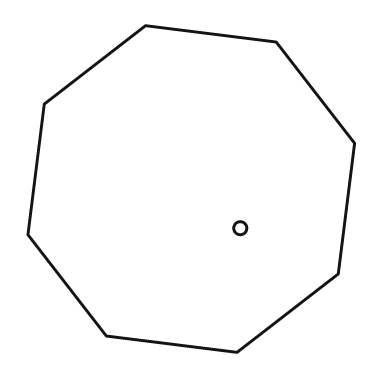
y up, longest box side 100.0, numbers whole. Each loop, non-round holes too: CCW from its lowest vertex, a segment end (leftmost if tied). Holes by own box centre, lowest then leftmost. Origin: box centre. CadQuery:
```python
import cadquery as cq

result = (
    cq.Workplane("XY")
    .moveTo(14.0, -50.0)
    .lineTo(45.0, -26.0)
    .lineTo(50.0, 14.0)
    .lineTo(26.0, 45.0)
    .lineTo(-14.0, 50.0)
    .lineTo(-45.0, 26.0)
    .lineTo(-50.0, -14.0)
    .lineTo(-26.0, -45.0)
    .close()
    .moveTo(15.0, -12.0)
    .circle(2.0)
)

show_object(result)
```